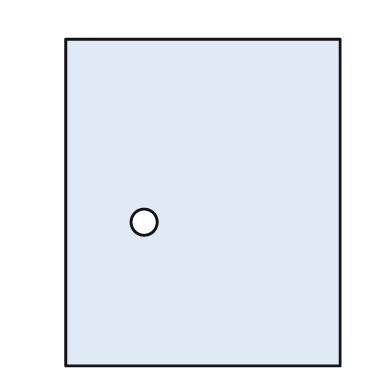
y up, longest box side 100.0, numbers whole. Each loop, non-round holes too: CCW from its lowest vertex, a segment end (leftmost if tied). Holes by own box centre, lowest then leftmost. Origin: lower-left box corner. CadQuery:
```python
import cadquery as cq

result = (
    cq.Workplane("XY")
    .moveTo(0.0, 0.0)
    .lineTo(84.0, 0.0)
    .lineTo(84.0, 100.0)
    .lineTo(0.0, 100.0)
    .close()
    .moveTo(24.0, 44.0)
    .circle(4.0)
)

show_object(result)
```